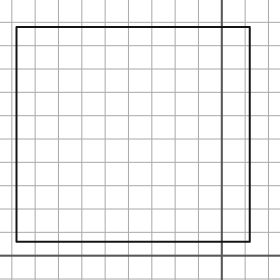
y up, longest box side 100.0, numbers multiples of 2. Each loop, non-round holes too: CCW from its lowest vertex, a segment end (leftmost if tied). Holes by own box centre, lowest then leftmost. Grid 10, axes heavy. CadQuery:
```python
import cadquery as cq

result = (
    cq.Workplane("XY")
    .moveTo(-88.0, 6.0)
    .lineTo(12.0, 6.0)
    .lineTo(12.0, 98.0)
    .lineTo(-88.0, 98.0)
    .close()
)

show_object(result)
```